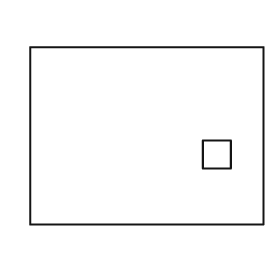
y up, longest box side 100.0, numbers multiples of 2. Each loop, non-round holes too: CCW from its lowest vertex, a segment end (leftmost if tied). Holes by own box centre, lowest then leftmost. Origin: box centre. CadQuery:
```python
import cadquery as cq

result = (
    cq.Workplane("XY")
    .moveTo(-50.0, -38.0)
    .lineTo(50.0, -38.0)
    .lineTo(50.0, 38.0)
    .lineTo(-50.0, 38.0)
    .close()
    .moveTo(24.0, -14.0)
    .lineTo(36.0, -14.0)
    .lineTo(36.0, -2.0)
    .lineTo(24.0, -2.0)
    .close()
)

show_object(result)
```